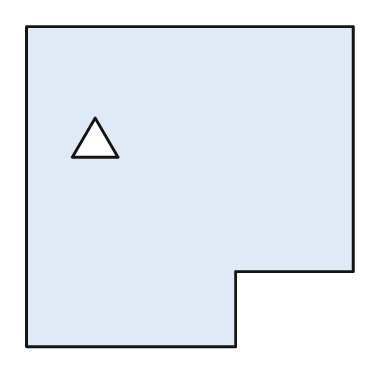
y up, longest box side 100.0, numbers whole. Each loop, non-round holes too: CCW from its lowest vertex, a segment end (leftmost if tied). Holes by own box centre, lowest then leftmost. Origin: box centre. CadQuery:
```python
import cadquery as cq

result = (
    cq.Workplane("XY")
    .moveTo(-50.0, -49.0)
    .lineTo(14.0, -49.0)
    .lineTo(14.0, -26.0)
    .lineTo(50.0, -26.0)
    .lineTo(50.0, 49.0)
    .lineTo(-50.0, 49.0)
    .close()
    .moveTo(-36.0, 9.0)
    .lineTo(-22.0, 9.0)
    .lineTo(-29.0, 21.0)
    .close()
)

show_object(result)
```